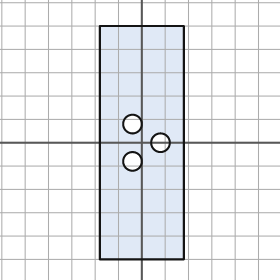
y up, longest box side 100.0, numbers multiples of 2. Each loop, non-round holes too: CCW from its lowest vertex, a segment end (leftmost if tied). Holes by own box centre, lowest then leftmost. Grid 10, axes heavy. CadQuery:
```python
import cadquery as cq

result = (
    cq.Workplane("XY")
    .moveTo(-18.0, -50.0)
    .lineTo(18.0, -50.0)
    .lineTo(18.0, 50.0)
    .lineTo(-18.0, 50.0)
    .close()
    .moveTo(-4.0, -8.0)
    .circle(4.0)
    .moveTo(8.0, 0.0)
    .circle(4.0)
    .moveTo(-4.0, 8.0)
    .circle(4.0)
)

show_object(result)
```